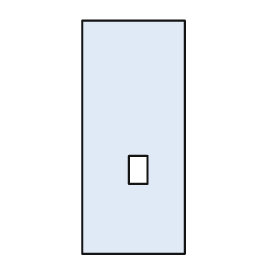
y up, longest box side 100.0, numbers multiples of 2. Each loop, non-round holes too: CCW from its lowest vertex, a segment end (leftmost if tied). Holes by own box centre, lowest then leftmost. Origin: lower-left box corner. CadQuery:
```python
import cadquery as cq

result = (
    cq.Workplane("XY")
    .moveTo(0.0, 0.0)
    .lineTo(44.0, 0.0)
    .lineTo(44.0, 100.0)
    .lineTo(0.0, 100.0)
    .close()
    .moveTo(20.0, 30.0)
    .lineTo(28.0, 30.0)
    .lineTo(28.0, 42.0)
    .lineTo(20.0, 42.0)
    .close()
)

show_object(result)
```